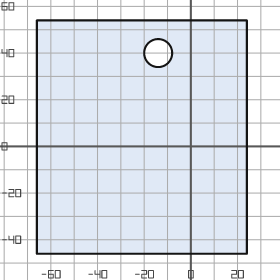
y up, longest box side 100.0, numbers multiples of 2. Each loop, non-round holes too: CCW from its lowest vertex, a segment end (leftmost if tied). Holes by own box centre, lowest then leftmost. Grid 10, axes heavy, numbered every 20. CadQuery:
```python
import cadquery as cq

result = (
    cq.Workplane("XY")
    .moveTo(-66.0, -46.0)
    .lineTo(24.0, -46.0)
    .lineTo(24.0, 54.0)
    .lineTo(-66.0, 54.0)
    .close()
    .moveTo(-14.0, 40.0)
    .circle(6.0)
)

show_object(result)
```